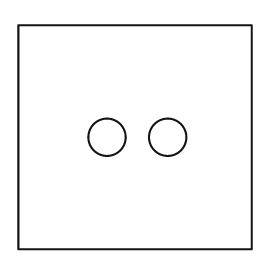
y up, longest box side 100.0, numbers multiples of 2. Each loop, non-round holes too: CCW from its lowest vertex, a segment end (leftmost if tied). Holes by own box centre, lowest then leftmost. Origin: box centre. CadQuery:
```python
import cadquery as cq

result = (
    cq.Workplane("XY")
    .moveTo(-50.0, -48.0)
    .lineTo(50.0, -48.0)
    .lineTo(50.0, 48.0)
    .lineTo(-50.0, 48.0)
    .close()
    .moveTo(-12.0, 0.0)
    .circle(8.0)
    .moveTo(14.0, 0.0)
    .circle(8.0)
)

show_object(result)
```